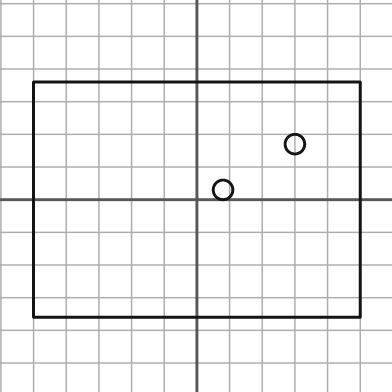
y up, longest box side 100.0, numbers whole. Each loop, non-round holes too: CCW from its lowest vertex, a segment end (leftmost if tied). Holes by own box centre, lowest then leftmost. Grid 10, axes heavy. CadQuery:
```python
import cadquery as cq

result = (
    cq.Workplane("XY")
    .moveTo(-50.0, -36.0)
    .lineTo(50.0, -36.0)
    .lineTo(50.0, 36.0)
    .lineTo(-50.0, 36.0)
    .close()
    .moveTo(8.0, 3.0)
    .circle(3.0)
    .moveTo(30.0, 17.0)
    .circle(3.0)
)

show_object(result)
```